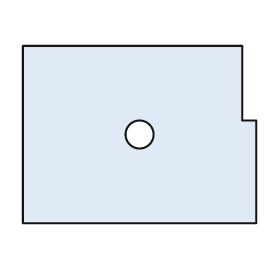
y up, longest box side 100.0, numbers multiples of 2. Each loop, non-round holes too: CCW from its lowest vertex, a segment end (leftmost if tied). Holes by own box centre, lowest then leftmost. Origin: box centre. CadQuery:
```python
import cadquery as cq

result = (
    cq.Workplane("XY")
    .moveTo(-50.0, -38.0)
    .lineTo(50.0, -38.0)
    .lineTo(50.0, 6.0)
    .lineTo(44.0, 6.0)
    .lineTo(44.0, 38.0)
    .lineTo(-50.0, 38.0)
    .close()
    .moveTo(0.0, 0.0)
    .circle(6.0)
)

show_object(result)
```